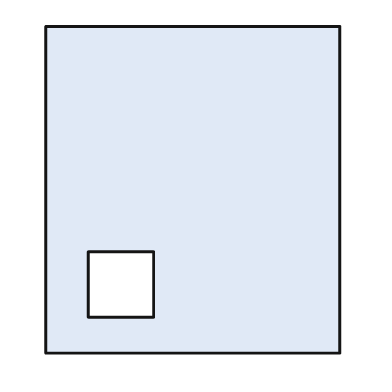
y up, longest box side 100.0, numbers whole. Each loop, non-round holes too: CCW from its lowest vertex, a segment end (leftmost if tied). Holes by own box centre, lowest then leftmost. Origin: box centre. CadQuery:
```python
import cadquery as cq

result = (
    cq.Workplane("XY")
    .moveTo(-45.0, -50.0)
    .lineTo(45.0, -50.0)
    .lineTo(45.0, 50.0)
    .lineTo(-45.0, 50.0)
    .close()
    .moveTo(-32.0, -39.0)
    .lineTo(-12.0, -39.0)
    .lineTo(-12.0, -19.0)
    .lineTo(-32.0, -19.0)
    .close()
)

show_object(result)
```